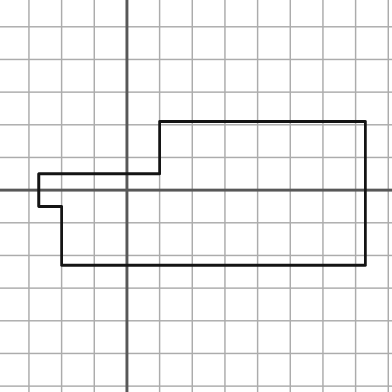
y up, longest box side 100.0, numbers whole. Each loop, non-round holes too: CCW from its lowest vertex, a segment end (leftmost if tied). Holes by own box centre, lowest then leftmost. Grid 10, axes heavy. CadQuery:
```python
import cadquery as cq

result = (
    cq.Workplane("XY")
    .moveTo(-20.0, -23.0)
    .lineTo(73.0, -23.0)
    .lineTo(73.0, 21.0)
    .lineTo(10.0, 21.0)
    .lineTo(10.0, 5.0)
    .lineTo(-27.0, 5.0)
    .lineTo(-27.0, -5.0)
    .lineTo(-20.0, -5.0)
    .close()
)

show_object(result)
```